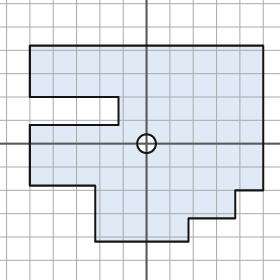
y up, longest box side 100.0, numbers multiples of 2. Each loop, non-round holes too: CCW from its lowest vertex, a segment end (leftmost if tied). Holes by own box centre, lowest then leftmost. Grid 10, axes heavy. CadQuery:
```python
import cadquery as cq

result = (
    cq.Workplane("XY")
    .moveTo(-22.0, -42.0)
    .lineTo(18.0, -42.0)
    .lineTo(18.0, -32.0)
    .lineTo(38.0, -32.0)
    .lineTo(38.0, -20.0)
    .lineTo(50.0, -20.0)
    .lineTo(50.0, 42.0)
    .lineTo(-50.0, 42.0)
    .lineTo(-50.0, 20.0)
    .lineTo(-12.0, 20.0)
    .lineTo(-12.0, 8.0)
    .lineTo(-50.0, 8.0)
    .lineTo(-50.0, -18.0)
    .lineTo(-22.0, -18.0)
    .close()
    .moveTo(0.0, 0.0)
    .circle(4.0)
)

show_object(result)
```